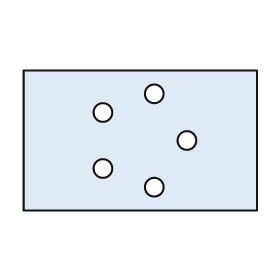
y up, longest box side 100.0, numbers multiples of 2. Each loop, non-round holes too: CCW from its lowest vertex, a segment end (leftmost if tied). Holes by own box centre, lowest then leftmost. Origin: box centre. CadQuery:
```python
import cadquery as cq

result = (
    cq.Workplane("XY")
    .moveTo(-50.0, -30.0)
    .lineTo(50.0, -30.0)
    .lineTo(50.0, 30.0)
    .lineTo(-50.0, 30.0)
    .close()
    .moveTo(6.0, -20.0)
    .circle(4.0)
    .moveTo(-16.0, -12.0)
    .circle(4.0)
    .moveTo(20.0, 0.0)
    .circle(4.0)
    .moveTo(-16.0, 12.0)
    .circle(4.0)
    .moveTo(6.0, 20.0)
    .circle(4.0)
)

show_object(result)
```